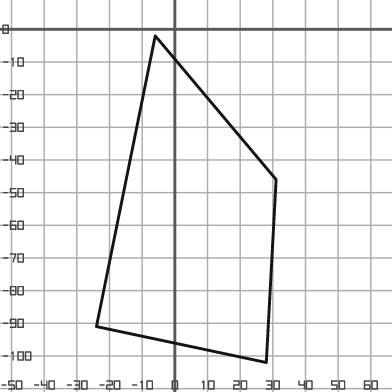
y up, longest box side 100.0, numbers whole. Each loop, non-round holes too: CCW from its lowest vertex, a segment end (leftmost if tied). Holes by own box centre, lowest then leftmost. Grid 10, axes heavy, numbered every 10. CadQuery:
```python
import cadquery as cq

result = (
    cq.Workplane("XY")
    .moveTo(28.0, -102.0)
    .lineTo(31.0, -46.0)
    .lineTo(-6.0, -2.0)
    .lineTo(-24.0, -91.0)
    .close()
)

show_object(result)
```